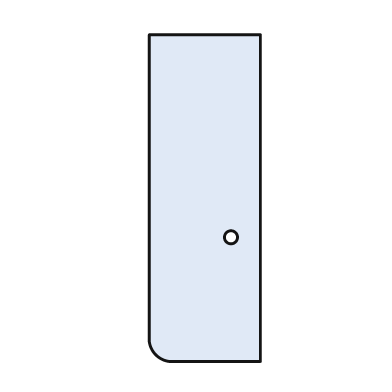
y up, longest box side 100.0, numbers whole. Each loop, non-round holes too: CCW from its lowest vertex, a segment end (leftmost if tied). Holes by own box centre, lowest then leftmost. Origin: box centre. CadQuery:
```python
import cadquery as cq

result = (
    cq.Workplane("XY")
    .moveTo(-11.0, -50.0)
    .lineTo(17.0, -50.0)
    .lineTo(17.0, 50.0)
    .lineTo(-17.0, 50.0)
    .lineTo(-17.0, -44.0)
    .threePointArc((-15.0, -48.0), (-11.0, -50.0))
    .close()
    .moveTo(8.0, -12.0)
    .circle(2.0)
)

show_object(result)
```